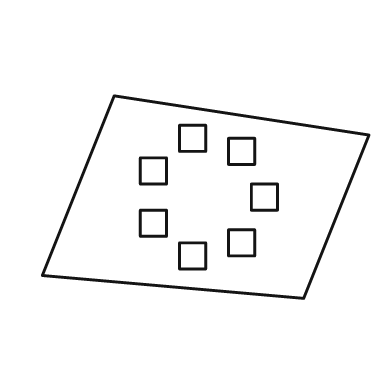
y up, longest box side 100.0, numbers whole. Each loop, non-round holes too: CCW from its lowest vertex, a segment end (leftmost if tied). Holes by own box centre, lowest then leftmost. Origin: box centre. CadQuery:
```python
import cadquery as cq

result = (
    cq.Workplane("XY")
    .moveTo(30.0, -31.0)
    .lineTo(50.0, 19.0)
    .lineTo(-28.0, 31.0)
    .lineTo(-50.0, -24.0)
    .close()
    .moveTo(-8.0, -22.0)
    .lineTo(0.0, -22.0)
    .lineTo(0.0, -14.0)
    .lineTo(-8.0, -14.0)
    .close()
    .moveTo(7.0, -18.0)
    .lineTo(15.0, -18.0)
    .lineTo(15.0, -10.0)
    .lineTo(7.0, -10.0)
    .close()
    .moveTo(-20.0, -12.0)
    .lineTo(-12.0, -12.0)
    .lineTo(-12.0, -4.0)
    .lineTo(-20.0, -4.0)
    .close()
    .moveTo(14.0, -4.0)
    .lineTo(22.0, -4.0)
    .lineTo(22.0, 4.0)
    .lineTo(14.0, 4.0)
    .close()
    .moveTo(-20.0, 4.0)
    .lineTo(-12.0, 4.0)
    .lineTo(-12.0, 12.0)
    .lineTo(-20.0, 12.0)
    .close()
    .moveTo(7.0, 10.0)
    .lineTo(15.0, 10.0)
    .lineTo(15.0, 18.0)
    .lineTo(7.0, 18.0)
    .close()
    .moveTo(-8.0, 14.0)
    .lineTo(0.0, 14.0)
    .lineTo(0.0, 22.0)
    .lineTo(-8.0, 22.0)
    .close()
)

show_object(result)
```